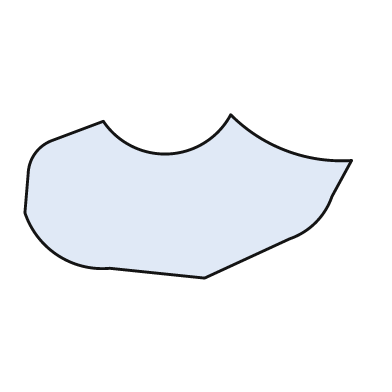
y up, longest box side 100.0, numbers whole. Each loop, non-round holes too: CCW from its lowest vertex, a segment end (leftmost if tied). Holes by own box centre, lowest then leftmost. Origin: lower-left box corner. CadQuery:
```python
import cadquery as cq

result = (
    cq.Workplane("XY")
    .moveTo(55.0, 0.0)
    .lineTo(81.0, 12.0)
    .threePointArc((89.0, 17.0), (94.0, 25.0))
    .lineTo(100.0, 36.0)
    .threePointArc((80.0, 39.0), (63.0, 50.0))
    .threePointArc((44.0, 38.0), (24.0, 48.0))
    .lineTo(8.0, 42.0)
    .threePointArc((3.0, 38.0), (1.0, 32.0))
    .lineTo(0.0, 20.0)
    .threePointArc((10.0, 7.0), (26.0, 3.0))
    .close()
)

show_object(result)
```